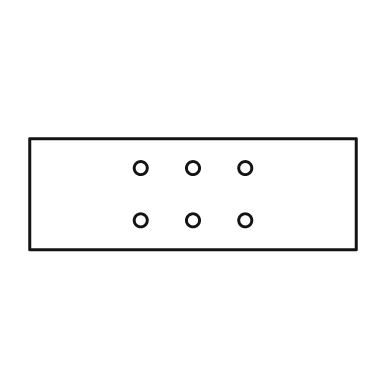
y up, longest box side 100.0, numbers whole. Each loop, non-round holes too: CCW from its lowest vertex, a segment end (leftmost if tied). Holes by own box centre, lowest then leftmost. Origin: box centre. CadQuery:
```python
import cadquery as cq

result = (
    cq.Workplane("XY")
    .moveTo(-50.0, -17.0)
    .lineTo(50.0, -17.0)
    .lineTo(50.0, 17.0)
    .lineTo(-50.0, 17.0)
    .close()
    .moveTo(-16.0, -8.0)
    .circle(2.0)
    .moveTo(0.0, -8.0)
    .circle(2.0)
    .moveTo(16.0, -8.0)
    .circle(2.0)
    .moveTo(-16.0, 8.0)
    .circle(2.0)
    .moveTo(0.0, 8.0)
    .circle(2.0)
    .moveTo(16.0, 8.0)
    .circle(2.0)
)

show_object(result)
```